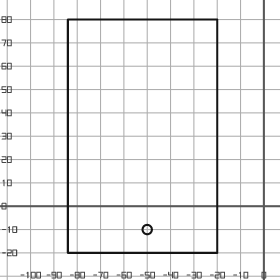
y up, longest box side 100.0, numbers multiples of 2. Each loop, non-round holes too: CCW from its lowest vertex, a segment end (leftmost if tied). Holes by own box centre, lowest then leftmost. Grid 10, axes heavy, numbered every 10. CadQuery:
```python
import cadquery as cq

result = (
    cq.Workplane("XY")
    .moveTo(-84.0, -20.0)
    .lineTo(-20.0, -20.0)
    .lineTo(-20.0, 80.0)
    .lineTo(-84.0, 80.0)
    .close()
    .moveTo(-50.0, -10.0)
    .circle(2.0)
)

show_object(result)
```